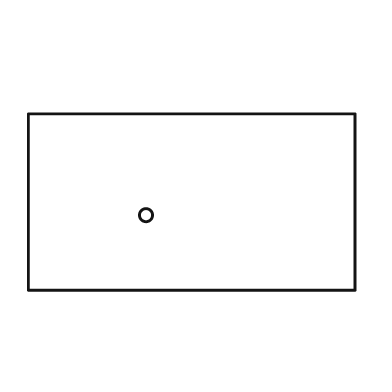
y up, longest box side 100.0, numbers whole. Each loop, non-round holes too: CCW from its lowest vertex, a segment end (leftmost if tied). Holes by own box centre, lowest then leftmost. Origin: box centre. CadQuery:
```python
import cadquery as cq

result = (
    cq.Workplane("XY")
    .moveTo(-50.0, -27.0)
    .lineTo(50.0, -27.0)
    .lineTo(50.0, 27.0)
    .lineTo(-50.0, 27.0)
    .close()
    .moveTo(-14.0, -4.0)
    .circle(2.0)
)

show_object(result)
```